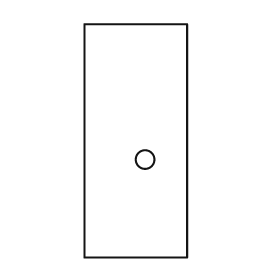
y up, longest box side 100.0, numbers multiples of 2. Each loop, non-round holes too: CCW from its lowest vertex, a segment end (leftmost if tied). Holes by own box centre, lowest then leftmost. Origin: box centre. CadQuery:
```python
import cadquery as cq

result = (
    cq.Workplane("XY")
    .moveTo(-22.0, -50.0)
    .lineTo(22.0, -50.0)
    .lineTo(22.0, 50.0)
    .lineTo(-22.0, 50.0)
    .close()
    .moveTo(4.0, -8.0)
    .circle(4.0)
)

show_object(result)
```